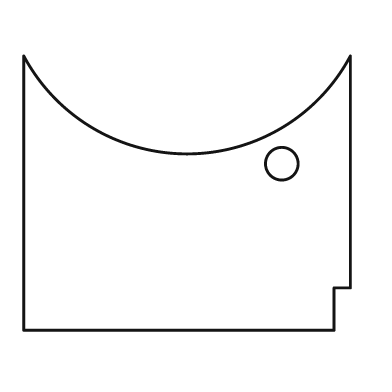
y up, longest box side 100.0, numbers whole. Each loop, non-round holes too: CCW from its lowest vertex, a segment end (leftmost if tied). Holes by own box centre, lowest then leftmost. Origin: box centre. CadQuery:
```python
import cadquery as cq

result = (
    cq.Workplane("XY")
    .moveTo(-50.0, -42.0)
    .lineTo(45.0, -42.0)
    .lineTo(45.0, -29.0)
    .lineTo(50.0, -29.0)
    .lineTo(50.0, 42.0)
    .threePointArc((0.0, 12.0), (-50.0, 42.0))
    .close()
    .moveTo(29.0, 9.0)
    .circle(5.0)
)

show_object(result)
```